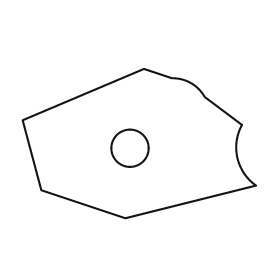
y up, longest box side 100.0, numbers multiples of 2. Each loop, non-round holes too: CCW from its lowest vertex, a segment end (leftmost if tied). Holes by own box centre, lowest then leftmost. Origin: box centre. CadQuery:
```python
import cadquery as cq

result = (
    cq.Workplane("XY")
    .moveTo(-6.0, -32.0)
    .lineTo(50.0, -18.0)
    .threePointArc((42.0, -6.0), (44.0, 8.0))
    .lineTo(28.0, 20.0)
    .threePointArc((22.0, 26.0), (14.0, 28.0))
    .lineTo(2.0, 32.0)
    .lineTo(-50.0, 10.0)
    .lineTo(-42.0, -20.0)
    .close()
    .moveTo(-4.0, -2.0)
    .circle(8.0)
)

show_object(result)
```